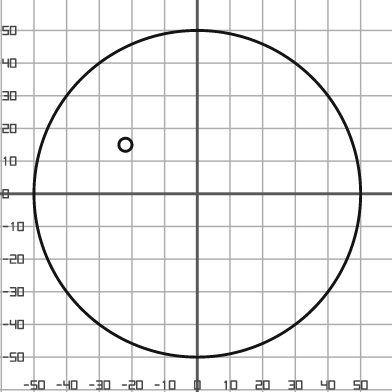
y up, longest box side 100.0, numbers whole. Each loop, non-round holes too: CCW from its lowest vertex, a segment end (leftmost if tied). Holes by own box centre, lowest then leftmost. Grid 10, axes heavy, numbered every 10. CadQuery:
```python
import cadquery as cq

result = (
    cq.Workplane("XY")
    .moveTo(0.0, 0.0)
    .circle(50.0)
    .moveTo(-22.0, 15.0)
    .circle(2.0)
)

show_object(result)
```